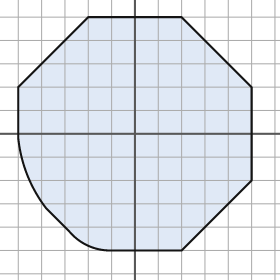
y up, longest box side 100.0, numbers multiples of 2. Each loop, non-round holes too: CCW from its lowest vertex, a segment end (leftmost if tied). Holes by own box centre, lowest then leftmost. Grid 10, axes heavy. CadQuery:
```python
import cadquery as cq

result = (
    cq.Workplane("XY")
    .moveTo(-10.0, -50.0)
    .lineTo(20.0, -50.0)
    .lineTo(50.0, -20.0)
    .lineTo(50.0, 20.0)
    .lineTo(20.0, 50.0)
    .lineTo(-20.0, 50.0)
    .lineTo(-50.0, 20.0)
    .lineTo(-50.0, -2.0)
    .threePointArc((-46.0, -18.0), (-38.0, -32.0))
    .lineTo(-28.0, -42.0)
    .threePointArc((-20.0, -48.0), (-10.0, -50.0))
    .close()
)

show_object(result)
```